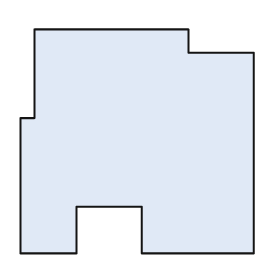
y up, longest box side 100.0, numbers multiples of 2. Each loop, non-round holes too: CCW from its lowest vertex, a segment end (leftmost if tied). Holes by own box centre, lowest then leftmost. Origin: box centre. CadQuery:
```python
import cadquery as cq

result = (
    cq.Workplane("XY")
    .moveTo(-50.0, -48.0)
    .lineTo(-26.0, -48.0)
    .lineTo(-26.0, -28.0)
    .lineTo(2.0, -28.0)
    .lineTo(2.0, -48.0)
    .lineTo(50.0, -48.0)
    .lineTo(50.0, 38.0)
    .lineTo(22.0, 38.0)
    .lineTo(22.0, 48.0)
    .lineTo(-44.0, 48.0)
    .lineTo(-44.0, 10.0)
    .lineTo(-50.0, 10.0)
    .close()
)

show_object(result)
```